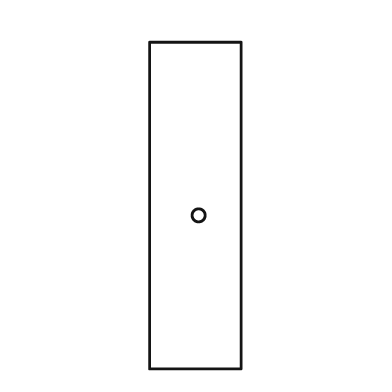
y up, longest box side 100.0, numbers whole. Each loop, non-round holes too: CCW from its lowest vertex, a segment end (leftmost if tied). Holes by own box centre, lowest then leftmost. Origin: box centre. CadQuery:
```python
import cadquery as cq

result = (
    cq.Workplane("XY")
    .moveTo(-14.0, -50.0)
    .lineTo(14.0, -50.0)
    .lineTo(14.0, 50.0)
    .lineTo(-14.0, 50.0)
    .close()
    .moveTo(1.0, -3.0)
    .circle(2.0)
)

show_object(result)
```